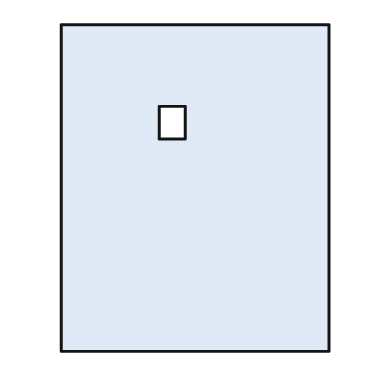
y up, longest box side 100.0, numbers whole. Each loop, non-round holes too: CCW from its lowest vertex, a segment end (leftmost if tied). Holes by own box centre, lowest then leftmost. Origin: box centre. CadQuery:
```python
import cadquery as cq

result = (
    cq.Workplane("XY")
    .moveTo(-41.0, -50.0)
    .lineTo(41.0, -50.0)
    .lineTo(41.0, 50.0)
    .lineTo(-41.0, 50.0)
    .close()
    .moveTo(-11.0, 15.0)
    .lineTo(-3.0, 15.0)
    .lineTo(-3.0, 25.0)
    .lineTo(-11.0, 25.0)
    .close()
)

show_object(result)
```